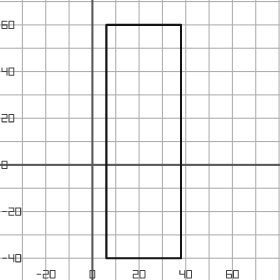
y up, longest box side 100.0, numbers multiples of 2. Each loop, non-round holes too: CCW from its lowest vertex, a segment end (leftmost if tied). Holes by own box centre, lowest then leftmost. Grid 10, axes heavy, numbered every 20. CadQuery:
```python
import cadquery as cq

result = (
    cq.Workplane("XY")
    .moveTo(6.0, -40.0)
    .lineTo(38.0, -40.0)
    .lineTo(38.0, 60.0)
    .lineTo(6.0, 60.0)
    .close()
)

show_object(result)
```